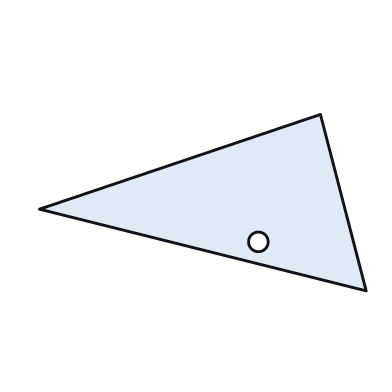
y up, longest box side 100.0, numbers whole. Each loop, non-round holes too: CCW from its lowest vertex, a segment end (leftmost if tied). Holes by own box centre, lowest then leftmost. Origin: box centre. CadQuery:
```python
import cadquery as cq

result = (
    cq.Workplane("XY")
    .moveTo(50.0, -27.0)
    .lineTo(36.0, 27.0)
    .lineTo(-50.0, -2.0)
    .close()
    .moveTo(17.0, -12.0)
    .circle(3.0)
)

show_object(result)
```